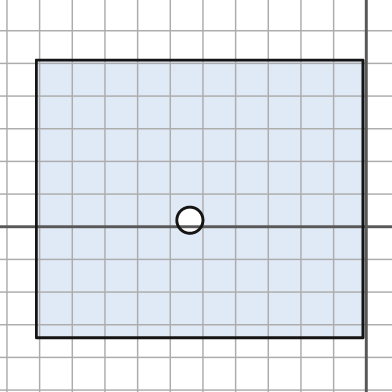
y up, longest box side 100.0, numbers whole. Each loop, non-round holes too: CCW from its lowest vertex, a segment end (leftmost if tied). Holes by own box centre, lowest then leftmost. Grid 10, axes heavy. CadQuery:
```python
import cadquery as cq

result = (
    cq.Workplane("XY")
    .moveTo(-101.0, -34.0)
    .lineTo(-1.0, -34.0)
    .lineTo(-1.0, 51.0)
    .lineTo(-101.0, 51.0)
    .close()
    .moveTo(-54.0, 2.0)
    .circle(4.0)
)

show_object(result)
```